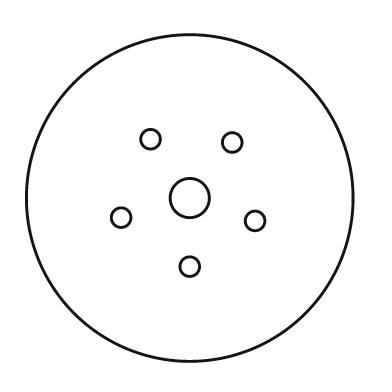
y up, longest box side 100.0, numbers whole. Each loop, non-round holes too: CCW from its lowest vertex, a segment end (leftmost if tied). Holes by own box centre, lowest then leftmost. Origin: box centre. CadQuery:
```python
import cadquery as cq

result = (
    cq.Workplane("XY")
    .moveTo(0.0, 0.0)
    .circle(50.0)
    .moveTo(0.0, -21.0)
    .circle(3.0)
    .moveTo(20.0, -7.0)
    .circle(3.0)
    .moveTo(-21.0, -6.0)
    .circle(3.0)
    .moveTo(0.0, 0.0)
    .circle(6.0)
    .moveTo(13.0, 17.0)
    .circle(3.0)
    .moveTo(-12.0, 18.0)
    .circle(3.0)
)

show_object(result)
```